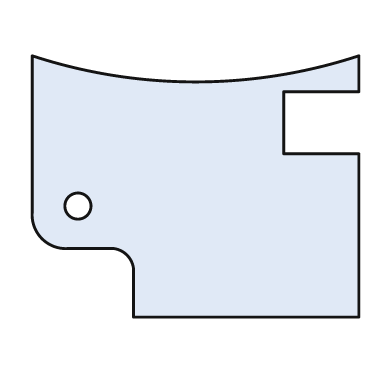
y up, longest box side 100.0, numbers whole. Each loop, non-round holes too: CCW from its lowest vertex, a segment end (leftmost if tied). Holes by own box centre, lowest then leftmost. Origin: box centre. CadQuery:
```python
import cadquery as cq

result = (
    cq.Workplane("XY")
    .moveTo(-19.0, -40.0)
    .lineTo(50.0, -40.0)
    .lineTo(50.0, 10.0)
    .lineTo(27.0, 10.0)
    .lineTo(27.0, 29.0)
    .lineTo(50.0, 29.0)
    .lineTo(50.0, 40.0)
    .threePointArc((0.0, 32.0), (-50.0, 40.0))
    .lineTo(-50.0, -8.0)
    .threePointArc((-47.0, -16.0), (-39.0, -19.0))
    .lineTo(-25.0, -19.0)
    .threePointArc((-21.0, -21.0), (-19.0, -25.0))
    .close()
    .moveTo(-36.0, -6.0)
    .circle(4.0)
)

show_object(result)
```